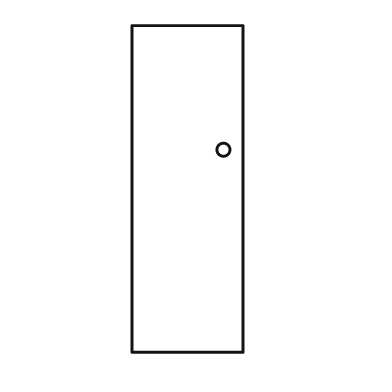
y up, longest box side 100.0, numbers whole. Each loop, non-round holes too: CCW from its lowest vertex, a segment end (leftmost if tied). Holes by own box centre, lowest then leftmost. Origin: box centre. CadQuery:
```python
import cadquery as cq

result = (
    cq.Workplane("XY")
    .moveTo(-17.0, -50.0)
    .lineTo(17.0, -50.0)
    .lineTo(17.0, 50.0)
    .lineTo(-17.0, 50.0)
    .close()
    .moveTo(11.0, 12.0)
    .circle(2.0)
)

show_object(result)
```